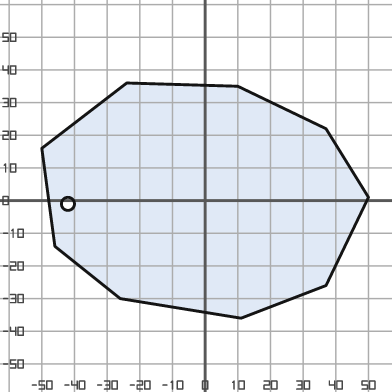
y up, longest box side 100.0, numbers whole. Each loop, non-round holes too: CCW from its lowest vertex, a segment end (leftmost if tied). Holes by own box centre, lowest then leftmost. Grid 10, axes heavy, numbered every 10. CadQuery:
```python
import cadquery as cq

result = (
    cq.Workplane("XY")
    .moveTo(11.0, -36.0)
    .lineTo(37.0, -26.0)
    .lineTo(50.0, 1.0)
    .lineTo(37.0, 22.0)
    .lineTo(10.0, 35.0)
    .lineTo(-24.0, 36.0)
    .lineTo(-50.0, 16.0)
    .lineTo(-46.0, -14.0)
    .lineTo(-26.0, -30.0)
    .close()
    .moveTo(-42.0, -1.0)
    .circle(2.0)
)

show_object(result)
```